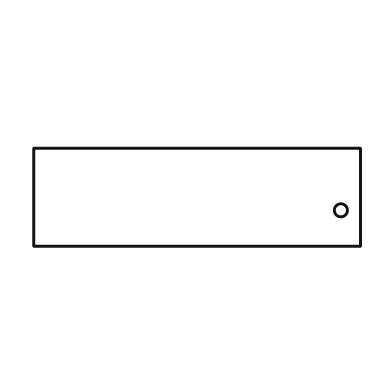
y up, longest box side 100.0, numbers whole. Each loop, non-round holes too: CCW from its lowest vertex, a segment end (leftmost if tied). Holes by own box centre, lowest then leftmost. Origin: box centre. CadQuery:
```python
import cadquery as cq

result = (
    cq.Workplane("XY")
    .moveTo(-50.0, -15.0)
    .lineTo(50.0, -15.0)
    .lineTo(50.0, 15.0)
    .lineTo(-50.0, 15.0)
    .close()
    .moveTo(44.0, -4.0)
    .circle(2.0)
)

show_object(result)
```